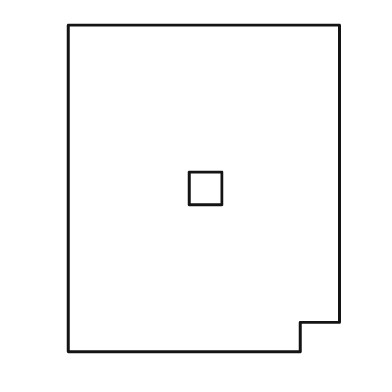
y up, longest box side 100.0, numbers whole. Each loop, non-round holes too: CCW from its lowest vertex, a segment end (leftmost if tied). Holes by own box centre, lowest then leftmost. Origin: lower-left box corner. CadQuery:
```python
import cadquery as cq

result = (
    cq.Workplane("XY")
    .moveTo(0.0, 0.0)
    .lineTo(71.0, 0.0)
    .lineTo(71.0, 9.0)
    .lineTo(83.0, 9.0)
    .lineTo(83.0, 100.0)
    .lineTo(0.0, 100.0)
    .close()
    .moveTo(37.0, 45.0)
    .lineTo(47.0, 45.0)
    .lineTo(47.0, 55.0)
    .lineTo(37.0, 55.0)
    .close()
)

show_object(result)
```